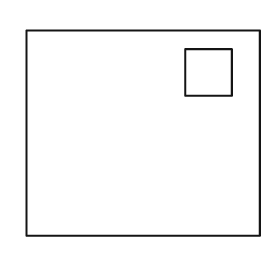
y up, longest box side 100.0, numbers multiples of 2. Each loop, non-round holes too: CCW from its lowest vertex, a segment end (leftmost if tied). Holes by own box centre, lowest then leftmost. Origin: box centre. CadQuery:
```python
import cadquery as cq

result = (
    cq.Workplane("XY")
    .moveTo(-50.0, -44.0)
    .lineTo(50.0, -44.0)
    .lineTo(50.0, 44.0)
    .lineTo(-50.0, 44.0)
    .close()
    .moveTo(18.0, 16.0)
    .lineTo(38.0, 16.0)
    .lineTo(38.0, 36.0)
    .lineTo(18.0, 36.0)
    .close()
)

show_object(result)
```